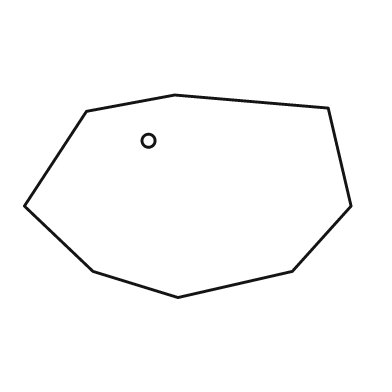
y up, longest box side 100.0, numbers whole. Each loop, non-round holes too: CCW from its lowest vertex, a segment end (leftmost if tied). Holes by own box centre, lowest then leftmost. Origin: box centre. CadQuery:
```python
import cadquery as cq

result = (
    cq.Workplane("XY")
    .moveTo(-3.0, -31.0)
    .lineTo(32.0, -23.0)
    .lineTo(50.0, -3.0)
    .lineTo(43.0, 27.0)
    .lineTo(-4.0, 31.0)
    .lineTo(-31.0, 26.0)
    .lineTo(-50.0, -3.0)
    .lineTo(-29.0, -23.0)
    .close()
    .moveTo(-12.0, 17.0)
    .circle(2.0)
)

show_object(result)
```